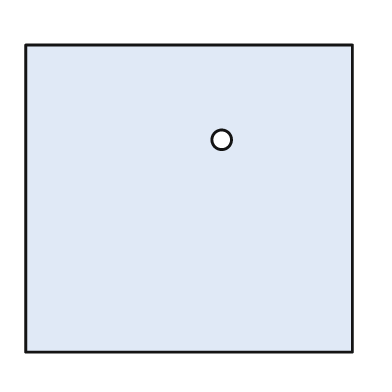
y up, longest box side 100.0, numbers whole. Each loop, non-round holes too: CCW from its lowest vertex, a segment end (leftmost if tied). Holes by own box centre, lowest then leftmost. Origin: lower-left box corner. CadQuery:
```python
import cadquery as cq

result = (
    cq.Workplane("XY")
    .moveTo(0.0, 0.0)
    .lineTo(100.0, 0.0)
    .lineTo(100.0, 94.0)
    .lineTo(0.0, 94.0)
    .close()
    .moveTo(60.0, 65.0)
    .circle(3.0)
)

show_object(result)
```